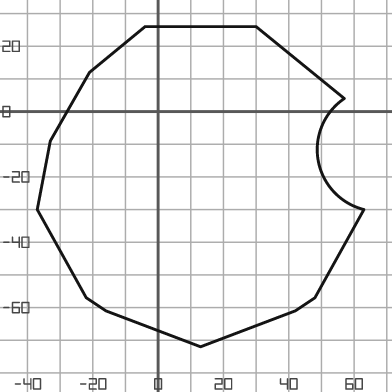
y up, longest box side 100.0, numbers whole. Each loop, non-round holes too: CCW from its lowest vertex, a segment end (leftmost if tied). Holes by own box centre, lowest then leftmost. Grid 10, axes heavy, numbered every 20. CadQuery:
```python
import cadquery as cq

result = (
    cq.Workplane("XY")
    .moveTo(13.0, -72.0)
    .lineTo(42.0, -61.0)
    .lineTo(48.0, -57.0)
    .lineTo(63.0, -30.0)
    .threePointArc((49.0, -15.0), (57.0, 4.0))
    .lineTo(30.0, 26.0)
    .lineTo(-4.0, 26.0)
    .lineTo(-21.0, 12.0)
    .lineTo(-33.0, -9.0)
    .lineTo(-37.0, -30.0)
    .lineTo(-22.0, -57.0)
    .lineTo(-16.0, -61.0)
    .close()
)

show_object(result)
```